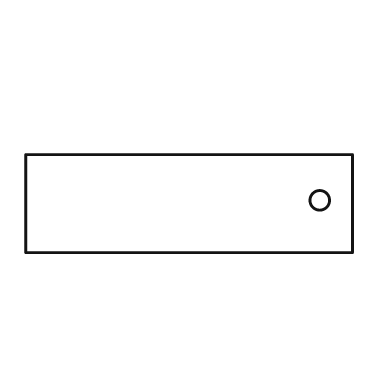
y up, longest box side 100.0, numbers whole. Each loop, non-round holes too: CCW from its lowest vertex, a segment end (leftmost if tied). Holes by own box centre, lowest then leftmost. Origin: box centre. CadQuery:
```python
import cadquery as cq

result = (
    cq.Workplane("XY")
    .moveTo(-50.0, -15.0)
    .lineTo(50.0, -15.0)
    .lineTo(50.0, 15.0)
    .lineTo(-50.0, 15.0)
    .close()
    .moveTo(40.0, 1.0)
    .circle(3.0)
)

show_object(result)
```